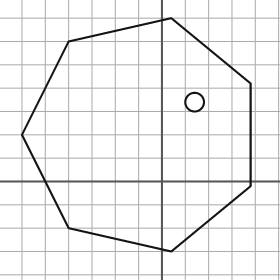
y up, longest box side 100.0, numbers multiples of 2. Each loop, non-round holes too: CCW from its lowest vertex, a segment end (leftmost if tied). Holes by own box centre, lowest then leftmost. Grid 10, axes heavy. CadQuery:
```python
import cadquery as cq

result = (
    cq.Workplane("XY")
    .moveTo(4.0, -30.0)
    .lineTo(38.0, -2.0)
    .lineTo(38.0, 42.0)
    .lineTo(4.0, 70.0)
    .lineTo(-40.0, 60.0)
    .lineTo(-60.0, 20.0)
    .lineTo(-40.0, -20.0)
    .close()
    .moveTo(14.0, 34.0)
    .circle(4.0)
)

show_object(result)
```